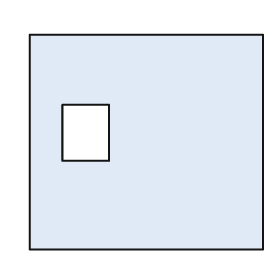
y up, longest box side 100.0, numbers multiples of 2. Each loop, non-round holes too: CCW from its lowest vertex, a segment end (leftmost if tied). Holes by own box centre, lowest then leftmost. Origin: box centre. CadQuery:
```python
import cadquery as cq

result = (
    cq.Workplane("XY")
    .moveTo(-50.0, -46.0)
    .lineTo(50.0, -46.0)
    .lineTo(50.0, 46.0)
    .lineTo(-50.0, 46.0)
    .close()
    .moveTo(-36.0, -8.0)
    .lineTo(-16.0, -8.0)
    .lineTo(-16.0, 16.0)
    .lineTo(-36.0, 16.0)
    .close()
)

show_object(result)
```